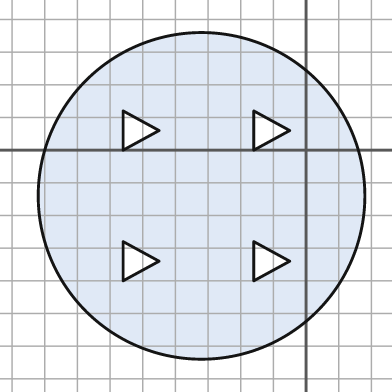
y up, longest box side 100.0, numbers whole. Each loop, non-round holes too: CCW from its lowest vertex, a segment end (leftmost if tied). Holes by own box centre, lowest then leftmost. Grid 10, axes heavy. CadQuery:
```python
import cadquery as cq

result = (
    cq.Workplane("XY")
    .moveTo(-32.0, -14.0)
    .circle(50.0)
    .moveTo(-56.0, -40.0)
    .lineTo(-45.0, -34.0)
    .lineTo(-56.0, -28.0)
    .close()
    .moveTo(-16.0, -40.0)
    .lineTo(-5.0, -34.0)
    .lineTo(-16.0, -28.0)
    .close()
    .moveTo(-56.0, 0.0)
    .lineTo(-45.0, 6.0)
    .lineTo(-56.0, 12.0)
    .close()
    .moveTo(-16.0, 0.0)
    .lineTo(-5.0, 6.0)
    .lineTo(-16.0, 12.0)
    .close()
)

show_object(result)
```